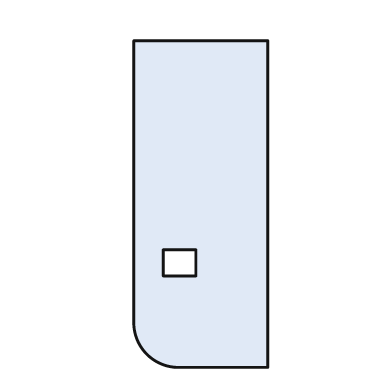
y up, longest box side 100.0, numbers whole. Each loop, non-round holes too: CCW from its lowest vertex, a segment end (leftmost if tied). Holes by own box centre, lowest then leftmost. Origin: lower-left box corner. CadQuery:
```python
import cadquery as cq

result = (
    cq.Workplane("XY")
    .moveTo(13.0, 0.0)
    .lineTo(41.0, 0.0)
    .lineTo(41.0, 100.0)
    .lineTo(0.0, 100.0)
    .lineTo(0.0, 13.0)
    .threePointArc((4.0, 4.0), (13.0, 0.0))
    .close()
    .moveTo(9.0, 28.0)
    .lineTo(19.0, 28.0)
    .lineTo(19.0, 36.0)
    .lineTo(9.0, 36.0)
    .close()
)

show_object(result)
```